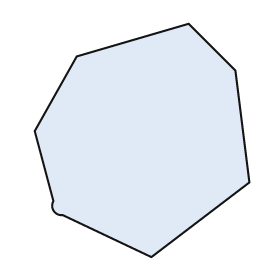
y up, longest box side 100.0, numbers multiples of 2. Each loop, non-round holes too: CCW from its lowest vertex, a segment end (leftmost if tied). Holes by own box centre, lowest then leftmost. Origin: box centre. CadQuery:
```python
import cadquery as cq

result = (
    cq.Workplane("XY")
    .moveTo(4.0, -50.0)
    .lineTo(46.0, -18.0)
    .lineTo(40.0, 30.0)
    .lineTo(20.0, 50.0)
    .lineTo(-28.0, 36.0)
    .lineTo(-46.0, 4.0)
    .lineTo(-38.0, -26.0)
    .threePointArc((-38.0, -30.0), (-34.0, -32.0))
    .close()
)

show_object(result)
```